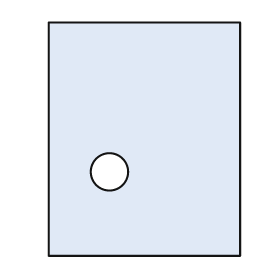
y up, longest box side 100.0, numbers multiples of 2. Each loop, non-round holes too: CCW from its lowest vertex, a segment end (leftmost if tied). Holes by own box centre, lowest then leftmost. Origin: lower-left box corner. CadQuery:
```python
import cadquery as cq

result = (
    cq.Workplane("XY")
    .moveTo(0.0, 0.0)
    .lineTo(82.0, 0.0)
    .lineTo(82.0, 100.0)
    .lineTo(0.0, 100.0)
    .close()
    .moveTo(26.0, 36.0)
    .circle(8.0)
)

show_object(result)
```